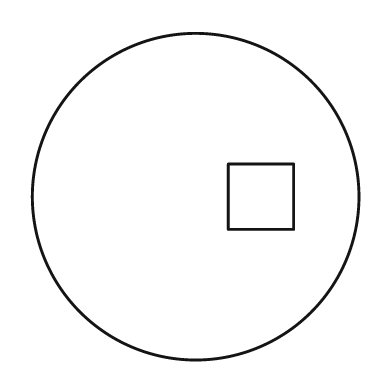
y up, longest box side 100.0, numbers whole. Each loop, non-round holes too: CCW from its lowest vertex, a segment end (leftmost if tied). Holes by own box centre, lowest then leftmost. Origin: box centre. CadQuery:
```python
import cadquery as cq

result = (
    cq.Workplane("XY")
    .moveTo(0.0, 0.0)
    .circle(50.0)
    .moveTo(10.0, -10.0)
    .lineTo(30.0, -10.0)
    .lineTo(30.0, 10.0)
    .lineTo(10.0, 10.0)
    .close()
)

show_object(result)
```